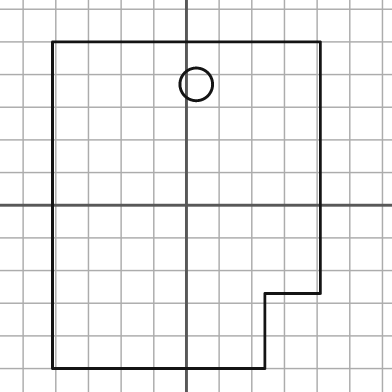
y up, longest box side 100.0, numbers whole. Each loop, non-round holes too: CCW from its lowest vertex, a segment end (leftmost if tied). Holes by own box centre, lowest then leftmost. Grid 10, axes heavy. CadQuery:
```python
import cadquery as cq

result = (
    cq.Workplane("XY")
    .moveTo(-41.0, -50.0)
    .lineTo(24.0, -50.0)
    .lineTo(24.0, -27.0)
    .lineTo(41.0, -27.0)
    .lineTo(41.0, 50.0)
    .lineTo(-41.0, 50.0)
    .close()
    .moveTo(3.0, 37.0)
    .circle(5.0)
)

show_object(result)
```